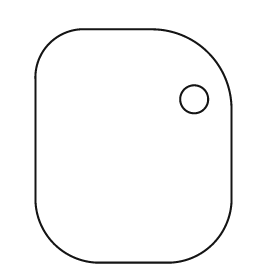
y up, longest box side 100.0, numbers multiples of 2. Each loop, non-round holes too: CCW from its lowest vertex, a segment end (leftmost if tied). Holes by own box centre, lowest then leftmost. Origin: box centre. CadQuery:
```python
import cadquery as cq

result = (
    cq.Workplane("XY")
    .moveTo(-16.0, -50.0)
    .lineTo(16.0, -50.0)
    .threePointArc((34.0, -42.0), (42.0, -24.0))
    .lineTo(42.0, 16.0)
    .threePointArc((32.0, 40.0), (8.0, 50.0))
    .lineTo(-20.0, 50.0)
    .threePointArc((-36.0, 44.0), (-42.0, 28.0))
    .lineTo(-42.0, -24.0)
    .threePointArc((-34.0, -42.0), (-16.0, -50.0))
    .close()
    .moveTo(26.0, 20.0)
    .circle(6.0)
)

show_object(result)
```